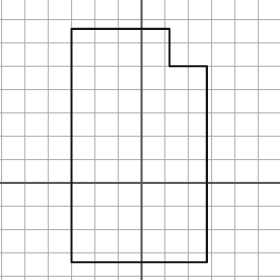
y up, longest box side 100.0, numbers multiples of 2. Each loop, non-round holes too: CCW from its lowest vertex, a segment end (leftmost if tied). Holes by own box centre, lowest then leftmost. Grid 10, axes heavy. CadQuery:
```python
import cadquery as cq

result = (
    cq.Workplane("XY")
    .moveTo(-30.0, -34.0)
    .lineTo(28.0, -34.0)
    .lineTo(28.0, 50.0)
    .lineTo(12.0, 50.0)
    .lineTo(12.0, 66.0)
    .lineTo(-30.0, 66.0)
    .close()
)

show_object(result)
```